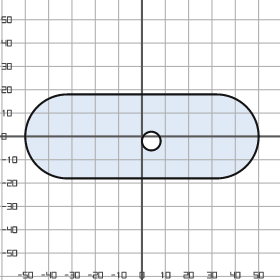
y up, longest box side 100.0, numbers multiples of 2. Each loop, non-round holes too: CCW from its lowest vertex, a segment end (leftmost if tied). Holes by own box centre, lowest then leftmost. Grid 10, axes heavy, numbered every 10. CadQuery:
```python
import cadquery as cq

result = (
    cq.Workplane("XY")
    .moveTo(-32.0, -18.0)
    .lineTo(32.0, -18.0)
    .threePointArc((50.0, 0.0), (32.0, 18.0))
    .lineTo(-32.0, 18.0)
    .threePointArc((-50.0, 0.0), (-32.0, -18.0))
    .close()
    .moveTo(4.0, -2.0)
    .circle(4.0)
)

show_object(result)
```